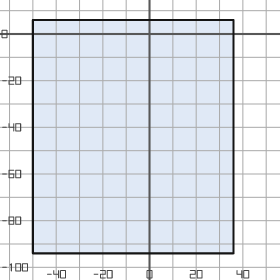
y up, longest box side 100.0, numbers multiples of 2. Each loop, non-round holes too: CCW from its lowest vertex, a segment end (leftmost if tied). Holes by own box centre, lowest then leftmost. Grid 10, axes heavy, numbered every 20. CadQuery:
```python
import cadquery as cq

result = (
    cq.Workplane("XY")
    .moveTo(-50.0, -94.0)
    .lineTo(36.0, -94.0)
    .lineTo(36.0, 6.0)
    .lineTo(-50.0, 6.0)
    .close()
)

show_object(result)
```